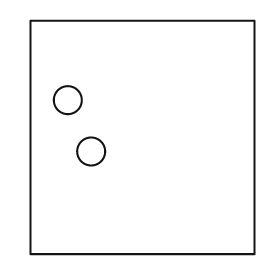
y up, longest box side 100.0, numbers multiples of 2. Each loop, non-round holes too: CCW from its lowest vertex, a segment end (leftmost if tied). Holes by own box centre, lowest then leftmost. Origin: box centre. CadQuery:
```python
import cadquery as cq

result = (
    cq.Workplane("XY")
    .moveTo(-48.0, -50.0)
    .lineTo(48.0, -50.0)
    .lineTo(48.0, 50.0)
    .lineTo(-48.0, 50.0)
    .close()
    .moveTo(-22.0, -6.0)
    .circle(6.0)
    .moveTo(-32.0, 16.0)
    .circle(6.0)
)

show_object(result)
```